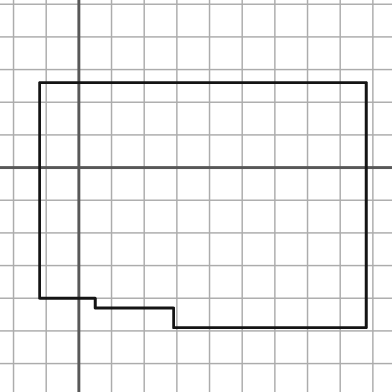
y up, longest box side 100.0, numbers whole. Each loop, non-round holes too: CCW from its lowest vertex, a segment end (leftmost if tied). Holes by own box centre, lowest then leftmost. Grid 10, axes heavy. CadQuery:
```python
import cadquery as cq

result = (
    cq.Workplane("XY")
    .moveTo(29.0, -49.0)
    .lineTo(88.0, -49.0)
    .lineTo(88.0, 26.0)
    .lineTo(-12.0, 26.0)
    .lineTo(-12.0, -40.0)
    .lineTo(5.0, -40.0)
    .lineTo(5.0, -43.0)
    .lineTo(29.0, -43.0)
    .close()
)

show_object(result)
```